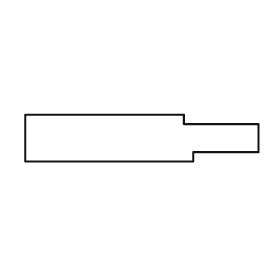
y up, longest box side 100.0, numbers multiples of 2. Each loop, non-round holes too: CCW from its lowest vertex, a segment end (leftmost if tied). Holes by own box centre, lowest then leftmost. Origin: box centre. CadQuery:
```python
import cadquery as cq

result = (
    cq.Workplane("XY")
    .moveTo(-50.0, -10.0)
    .lineTo(22.0, -10.0)
    .lineTo(22.0, -6.0)
    .lineTo(50.0, -6.0)
    .lineTo(50.0, 6.0)
    .lineTo(18.0, 6.0)
    .lineTo(18.0, 10.0)
    .lineTo(-50.0, 10.0)
    .close()
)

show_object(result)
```